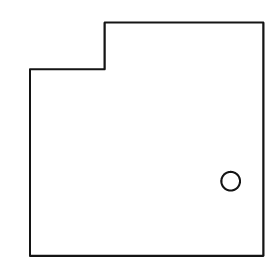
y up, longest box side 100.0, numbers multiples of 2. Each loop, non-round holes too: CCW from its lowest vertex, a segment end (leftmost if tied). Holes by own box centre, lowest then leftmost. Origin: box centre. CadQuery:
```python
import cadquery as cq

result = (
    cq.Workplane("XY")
    .moveTo(-50.0, -50.0)
    .lineTo(50.0, -50.0)
    .lineTo(50.0, 50.0)
    .lineTo(-18.0, 50.0)
    .lineTo(-18.0, 30.0)
    .lineTo(-50.0, 30.0)
    .close()
    .moveTo(36.0, -18.0)
    .circle(4.0)
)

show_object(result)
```